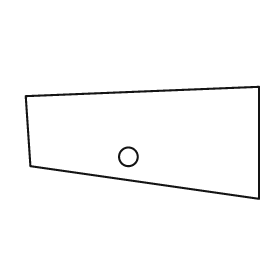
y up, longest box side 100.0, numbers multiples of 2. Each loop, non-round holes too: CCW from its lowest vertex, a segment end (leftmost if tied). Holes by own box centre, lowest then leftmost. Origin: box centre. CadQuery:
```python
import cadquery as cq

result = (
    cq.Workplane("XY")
    .moveTo(50.0, -24.0)
    .lineTo(50.0, 24.0)
    .lineTo(-50.0, 20.0)
    .lineTo(-48.0, -10.0)
    .close()
    .moveTo(-6.0, -6.0)
    .circle(4.0)
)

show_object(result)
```